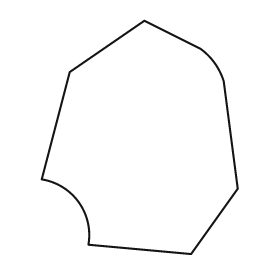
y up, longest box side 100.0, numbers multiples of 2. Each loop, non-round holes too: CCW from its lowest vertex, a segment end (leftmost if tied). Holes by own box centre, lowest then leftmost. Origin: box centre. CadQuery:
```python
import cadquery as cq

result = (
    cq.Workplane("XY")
    .moveTo(22.0, -50.0)
    .lineTo(42.0, -22.0)
    .lineTo(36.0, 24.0)
    .threePointArc((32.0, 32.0), (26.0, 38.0))
    .lineTo(2.0, 50.0)
    .lineTo(-30.0, 28.0)
    .lineTo(-42.0, -18.0)
    .threePointArc((-26.0, -28.0), (-22.0, -46.0))
    .close()
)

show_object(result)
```